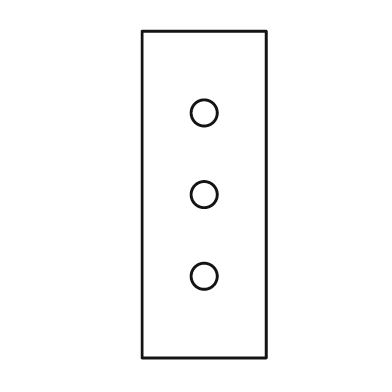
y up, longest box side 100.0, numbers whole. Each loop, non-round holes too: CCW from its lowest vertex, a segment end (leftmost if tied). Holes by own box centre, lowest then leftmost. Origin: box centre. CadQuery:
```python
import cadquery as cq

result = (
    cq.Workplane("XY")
    .moveTo(-19.0, -50.0)
    .lineTo(19.0, -50.0)
    .lineTo(19.0, 50.0)
    .lineTo(-19.0, 50.0)
    .close()
    .moveTo(0.0, -25.0)
    .circle(4.0)
    .moveTo(0.0, 0.0)
    .circle(4.0)
    .moveTo(0.0, 25.0)
    .circle(4.0)
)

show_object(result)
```